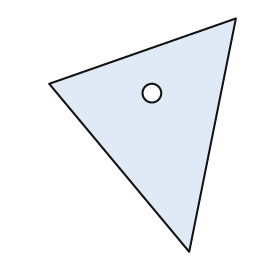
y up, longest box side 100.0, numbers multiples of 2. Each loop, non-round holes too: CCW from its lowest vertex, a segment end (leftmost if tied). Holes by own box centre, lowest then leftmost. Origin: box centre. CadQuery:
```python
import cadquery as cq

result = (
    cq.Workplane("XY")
    .moveTo(20.0, -50.0)
    .lineTo(40.0, 50.0)
    .lineTo(-40.0, 22.0)
    .close()
    .moveTo(4.0, 18.0)
    .circle(4.0)
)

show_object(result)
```